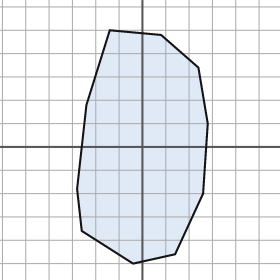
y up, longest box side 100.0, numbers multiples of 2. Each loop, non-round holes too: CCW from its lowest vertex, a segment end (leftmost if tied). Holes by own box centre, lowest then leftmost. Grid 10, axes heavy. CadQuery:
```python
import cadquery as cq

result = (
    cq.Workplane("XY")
    .moveTo(-4.0, -50.0)
    .lineTo(14.0, -46.0)
    .lineTo(26.0, -20.0)
    .lineTo(28.0, 10.0)
    .lineTo(24.0, 34.0)
    .lineTo(8.0, 48.0)
    .lineTo(-14.0, 50.0)
    .lineTo(-24.0, 18.0)
    .lineTo(-28.0, -18.0)
    .lineTo(-26.0, -36.0)
    .close()
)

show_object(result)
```